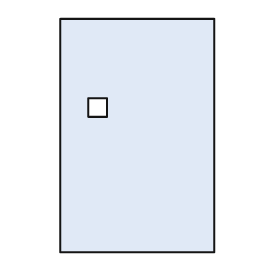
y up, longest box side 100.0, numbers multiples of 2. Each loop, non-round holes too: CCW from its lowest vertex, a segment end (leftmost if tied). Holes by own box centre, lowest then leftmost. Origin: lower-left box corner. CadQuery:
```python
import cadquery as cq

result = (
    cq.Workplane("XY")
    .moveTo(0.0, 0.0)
    .lineTo(66.0, 0.0)
    .lineTo(66.0, 100.0)
    .lineTo(0.0, 100.0)
    .close()
    .moveTo(12.0, 58.0)
    .lineTo(20.0, 58.0)
    .lineTo(20.0, 66.0)
    .lineTo(12.0, 66.0)
    .close()
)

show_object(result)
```